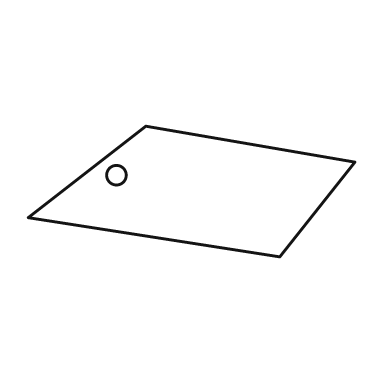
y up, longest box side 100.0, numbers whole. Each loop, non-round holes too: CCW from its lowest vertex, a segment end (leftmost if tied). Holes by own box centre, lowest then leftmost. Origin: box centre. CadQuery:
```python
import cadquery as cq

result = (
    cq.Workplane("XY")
    .moveTo(27.0, -20.0)
    .lineTo(50.0, 9.0)
    .lineTo(-14.0, 20.0)
    .lineTo(-50.0, -8.0)
    .close()
    .moveTo(-23.0, 5.0)
    .circle(3.0)
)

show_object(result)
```